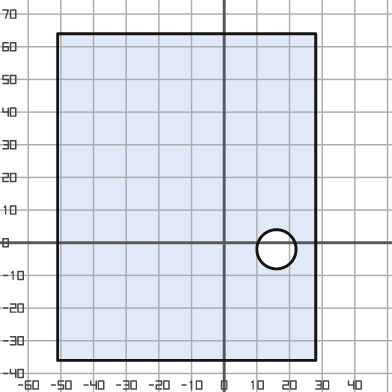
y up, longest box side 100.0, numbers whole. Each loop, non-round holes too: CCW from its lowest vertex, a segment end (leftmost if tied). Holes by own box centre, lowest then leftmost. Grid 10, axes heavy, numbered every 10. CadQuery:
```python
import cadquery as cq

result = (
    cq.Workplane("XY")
    .moveTo(-51.0, -36.0)
    .lineTo(28.0, -36.0)
    .lineTo(28.0, 64.0)
    .lineTo(-51.0, 64.0)
    .close()
    .moveTo(16.0, -2.0)
    .circle(6.0)
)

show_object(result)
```